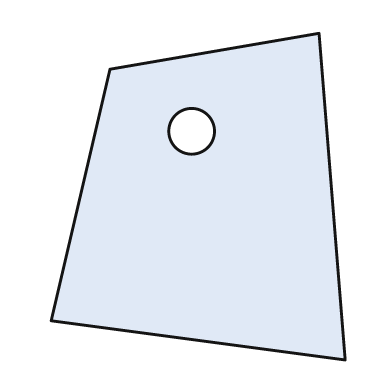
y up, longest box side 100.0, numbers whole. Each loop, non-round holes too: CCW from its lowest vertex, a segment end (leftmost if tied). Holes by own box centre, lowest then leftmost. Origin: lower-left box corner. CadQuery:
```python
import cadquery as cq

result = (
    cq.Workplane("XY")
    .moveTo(90.0, 0.0)
    .lineTo(82.0, 100.0)
    .lineTo(18.0, 89.0)
    .lineTo(0.0, 12.0)
    .close()
    .moveTo(43.0, 70.0)
    .circle(7.0)
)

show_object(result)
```